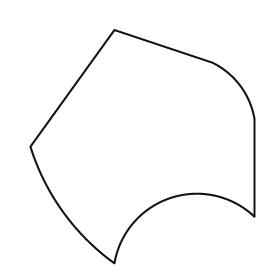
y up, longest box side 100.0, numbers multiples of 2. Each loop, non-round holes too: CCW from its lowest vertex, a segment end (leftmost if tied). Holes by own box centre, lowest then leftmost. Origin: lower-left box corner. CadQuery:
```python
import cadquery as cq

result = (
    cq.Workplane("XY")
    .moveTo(36.0, 0.0)
    .threePointArc((60.0, 28.0), (96.0, 20.0))
    .lineTo(96.0, 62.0)
    .threePointArc((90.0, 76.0), (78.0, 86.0))
    .lineTo(36.0, 100.0)
    .lineTo(0.0, 50.0)
    .threePointArc((14.0, 22.0), (36.0, 0.0))
    .close()
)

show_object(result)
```